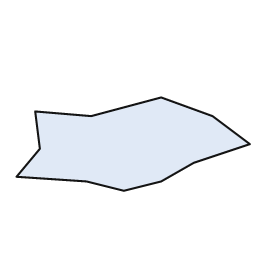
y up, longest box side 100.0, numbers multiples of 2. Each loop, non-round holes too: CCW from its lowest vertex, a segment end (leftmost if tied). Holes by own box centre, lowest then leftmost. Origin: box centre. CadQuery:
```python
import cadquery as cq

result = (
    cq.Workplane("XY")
    .moveTo(-4.0, -20.0)
    .lineTo(12.0, -16.0)
    .lineTo(26.0, -8.0)
    .lineTo(50.0, 0.0)
    .lineTo(34.0, 12.0)
    .lineTo(12.0, 20.0)
    .lineTo(-18.0, 12.0)
    .lineTo(-42.0, 14.0)
    .lineTo(-40.0, -2.0)
    .lineTo(-50.0, -14.0)
    .lineTo(-20.0, -16.0)
    .close()
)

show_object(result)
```